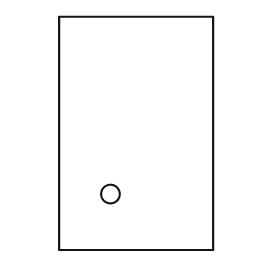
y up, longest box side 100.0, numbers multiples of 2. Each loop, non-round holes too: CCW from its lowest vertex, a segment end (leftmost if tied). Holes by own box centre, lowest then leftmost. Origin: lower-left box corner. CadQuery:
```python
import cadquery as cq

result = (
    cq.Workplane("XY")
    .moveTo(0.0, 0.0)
    .lineTo(66.0, 0.0)
    .lineTo(66.0, 100.0)
    .lineTo(0.0, 100.0)
    .close()
    .moveTo(22.0, 24.0)
    .circle(4.0)
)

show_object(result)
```